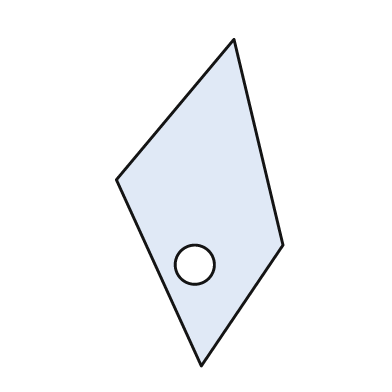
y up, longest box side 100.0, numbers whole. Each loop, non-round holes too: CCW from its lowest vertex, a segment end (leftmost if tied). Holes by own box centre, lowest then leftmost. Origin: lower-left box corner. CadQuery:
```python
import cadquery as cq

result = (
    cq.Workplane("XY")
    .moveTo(26.0, 0.0)
    .lineTo(51.0, 37.0)
    .lineTo(36.0, 100.0)
    .lineTo(0.0, 57.0)
    .close()
    .moveTo(24.0, 31.0)
    .circle(6.0)
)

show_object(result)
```